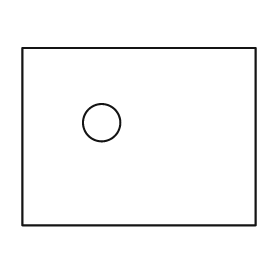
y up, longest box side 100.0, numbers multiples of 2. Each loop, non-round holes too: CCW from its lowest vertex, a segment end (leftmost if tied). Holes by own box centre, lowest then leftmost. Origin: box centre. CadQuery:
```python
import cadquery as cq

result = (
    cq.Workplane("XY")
    .moveTo(-50.0, -38.0)
    .lineTo(50.0, -38.0)
    .lineTo(50.0, 38.0)
    .lineTo(-50.0, 38.0)
    .close()
    .moveTo(-16.0, 6.0)
    .circle(8.0)
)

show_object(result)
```